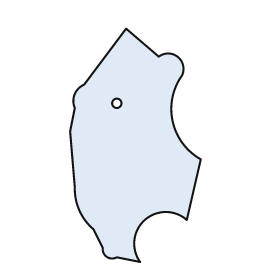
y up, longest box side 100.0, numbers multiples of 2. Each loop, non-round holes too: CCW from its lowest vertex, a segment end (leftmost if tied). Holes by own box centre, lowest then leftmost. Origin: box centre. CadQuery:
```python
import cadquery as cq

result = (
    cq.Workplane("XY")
    .moveTo(2.0, -50.0)
    .threePointArc((4.0, -32.0), (22.0, -32.0))
    .lineTo(28.0, -6.0)
    .threePointArc((16.0, 10.0), (20.0, 30.0))
    .threePointArc((18.0, 38.0), (10.0, 38.0))
    .lineTo(-4.0, 50.0)
    .lineTo(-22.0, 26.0)
    .threePointArc((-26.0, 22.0), (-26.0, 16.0))
    .lineTo(-28.0, 6.0)
    .lineTo(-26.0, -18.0)
    .threePointArc((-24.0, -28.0), (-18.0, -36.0))
    .lineTo(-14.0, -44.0)
    .threePointArc((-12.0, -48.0), (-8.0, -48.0))
    .close()
    .moveTo(-8.0, 18.0)
    .circle(2.0)
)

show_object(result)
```